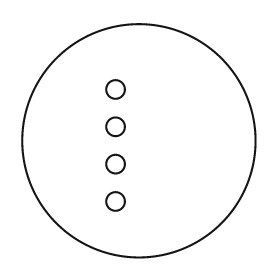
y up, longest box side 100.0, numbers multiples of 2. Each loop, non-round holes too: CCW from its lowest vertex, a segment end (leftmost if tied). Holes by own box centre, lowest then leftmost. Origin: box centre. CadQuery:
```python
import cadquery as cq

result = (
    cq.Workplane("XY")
    .moveTo(0.0, 0.0)
    .circle(50.0)
    .moveTo(-10.0, -26.0)
    .circle(4.0)
    .moveTo(-10.0, -10.0)
    .circle(4.0)
    .moveTo(-10.0, 6.0)
    .circle(4.0)
    .moveTo(-10.0, 22.0)
    .circle(4.0)
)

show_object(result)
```